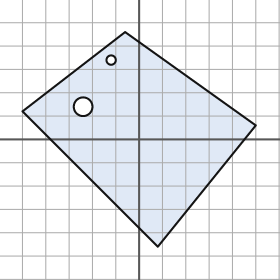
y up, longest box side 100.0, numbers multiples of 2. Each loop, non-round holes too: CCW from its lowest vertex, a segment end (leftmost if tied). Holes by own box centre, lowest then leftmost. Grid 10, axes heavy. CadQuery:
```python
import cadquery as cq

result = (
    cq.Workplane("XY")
    .moveTo(8.0, -46.0)
    .lineTo(50.0, 6.0)
    .lineTo(-6.0, 46.0)
    .lineTo(-50.0, 12.0)
    .close()
    .moveTo(-24.0, 14.0)
    .circle(4.0)
    .moveTo(-12.0, 34.0)
    .circle(2.0)
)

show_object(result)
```